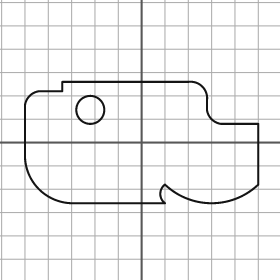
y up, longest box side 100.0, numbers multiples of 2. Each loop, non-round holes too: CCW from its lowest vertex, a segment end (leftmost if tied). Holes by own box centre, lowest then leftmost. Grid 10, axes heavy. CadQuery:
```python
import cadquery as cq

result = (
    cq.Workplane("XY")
    .moveTo(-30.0, -26.0)
    .lineTo(10.0, -26.0)
    .threePointArc((8.0, -22.0), (10.0, -18.0))
    .threePointArc((30.0, -26.0), (50.0, -18.0))
    .lineTo(50.0, 8.0)
    .lineTo(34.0, 8.0)
    .threePointArc((30.0, 10.0), (28.0, 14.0))
    .lineTo(28.0, 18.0)
    .threePointArc((26.0, 24.0), (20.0, 26.0))
    .lineTo(-34.0, 26.0)
    .lineTo(-34.0, 22.0)
    .lineTo(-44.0, 22.0)
    .threePointArc((-48.0, 20.0), (-50.0, 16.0))
    .lineTo(-50.0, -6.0)
    .threePointArc((-44.0, -20.0), (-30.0, -26.0))
    .close()
    .moveTo(-22.0, 14.0)
    .circle(6.0)
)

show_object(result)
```